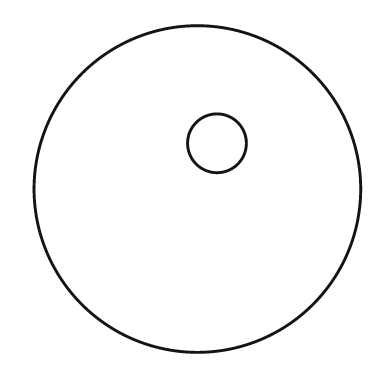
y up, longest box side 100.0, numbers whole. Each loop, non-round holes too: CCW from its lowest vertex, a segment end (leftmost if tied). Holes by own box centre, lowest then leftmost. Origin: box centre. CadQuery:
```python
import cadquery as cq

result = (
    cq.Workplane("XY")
    .moveTo(0.0, 0.0)
    .circle(50.0)
    .moveTo(6.0, 14.0)
    .circle(9.0)
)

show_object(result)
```